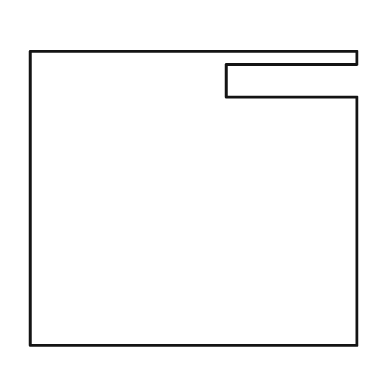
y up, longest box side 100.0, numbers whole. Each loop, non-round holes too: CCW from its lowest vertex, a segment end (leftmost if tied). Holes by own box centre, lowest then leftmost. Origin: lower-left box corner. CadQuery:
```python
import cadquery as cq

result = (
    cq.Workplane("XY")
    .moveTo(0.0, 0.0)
    .lineTo(100.0, 0.0)
    .lineTo(100.0, 76.0)
    .lineTo(60.0, 76.0)
    .lineTo(60.0, 86.0)
    .lineTo(100.0, 86.0)
    .lineTo(100.0, 90.0)
    .lineTo(0.0, 90.0)
    .close()
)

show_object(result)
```